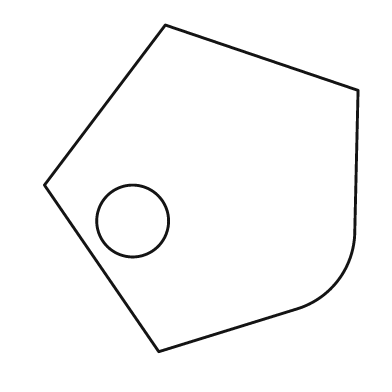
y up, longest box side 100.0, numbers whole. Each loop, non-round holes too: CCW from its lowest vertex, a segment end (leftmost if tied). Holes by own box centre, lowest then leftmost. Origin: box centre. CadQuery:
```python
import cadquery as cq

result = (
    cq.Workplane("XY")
    .moveTo(-13.0, -50.0)
    .lineTo(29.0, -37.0)
    .threePointArc((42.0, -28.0), (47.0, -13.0))
    .lineTo(48.0, 30.0)
    .lineTo(-11.0, 50.0)
    .lineTo(-48.0, 1.0)
    .close()
    .moveTo(-21.0, -10.0)
    .circle(11.0)
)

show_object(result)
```